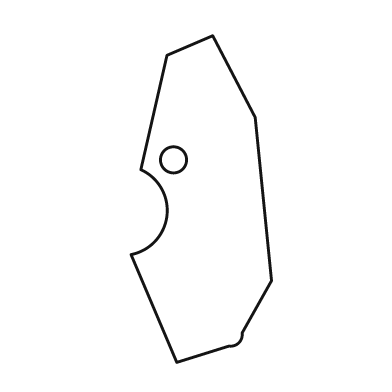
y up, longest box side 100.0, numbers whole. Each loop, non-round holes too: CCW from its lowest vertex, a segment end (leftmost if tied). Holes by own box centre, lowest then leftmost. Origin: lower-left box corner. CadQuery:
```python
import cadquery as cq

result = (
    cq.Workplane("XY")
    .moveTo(14.0, 0.0)
    .lineTo(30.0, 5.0)
    .threePointArc((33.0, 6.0), (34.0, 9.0))
    .lineTo(43.0, 25.0)
    .lineTo(38.0, 75.0)
    .lineTo(25.0, 100.0)
    .lineTo(11.0, 94.0)
    .lineTo(3.0, 59.0)
    .threePointArc((11.0, 45.0), (0.0, 33.0))
    .close()
    .moveTo(13.0, 62.0)
    .circle(4.0)
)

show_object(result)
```